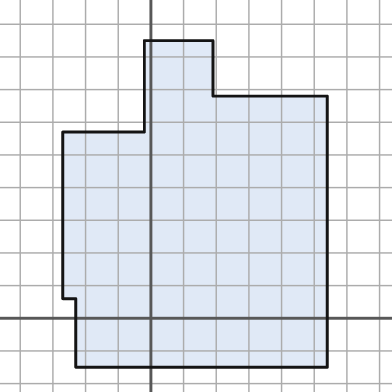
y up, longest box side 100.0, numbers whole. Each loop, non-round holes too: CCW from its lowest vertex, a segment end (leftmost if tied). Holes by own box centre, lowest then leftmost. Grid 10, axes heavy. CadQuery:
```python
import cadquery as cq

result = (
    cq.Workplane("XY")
    .moveTo(-23.0, -15.0)
    .lineTo(54.0, -15.0)
    .lineTo(54.0, 68.0)
    .lineTo(19.0, 68.0)
    .lineTo(19.0, 85.0)
    .lineTo(-2.0, 85.0)
    .lineTo(-2.0, 57.0)
    .lineTo(-27.0, 57.0)
    .lineTo(-27.0, 6.0)
    .lineTo(-23.0, 6.0)
    .close()
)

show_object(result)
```